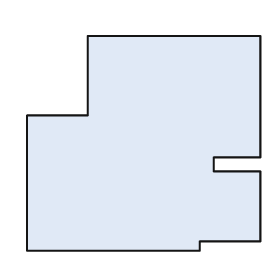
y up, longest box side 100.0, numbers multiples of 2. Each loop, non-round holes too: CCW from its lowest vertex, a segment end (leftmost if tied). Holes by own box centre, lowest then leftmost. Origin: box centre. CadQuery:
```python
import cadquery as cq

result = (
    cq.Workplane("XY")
    .moveTo(-50.0, -46.0)
    .lineTo(24.0, -46.0)
    .lineTo(24.0, -42.0)
    .lineTo(50.0, -42.0)
    .lineTo(50.0, -12.0)
    .lineTo(30.0, -12.0)
    .lineTo(30.0, -6.0)
    .lineTo(50.0, -6.0)
    .lineTo(50.0, 46.0)
    .lineTo(-24.0, 46.0)
    .lineTo(-24.0, 12.0)
    .lineTo(-50.0, 12.0)
    .close()
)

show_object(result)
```